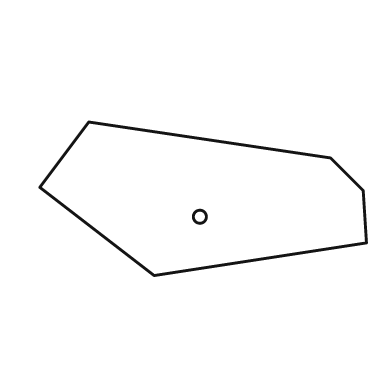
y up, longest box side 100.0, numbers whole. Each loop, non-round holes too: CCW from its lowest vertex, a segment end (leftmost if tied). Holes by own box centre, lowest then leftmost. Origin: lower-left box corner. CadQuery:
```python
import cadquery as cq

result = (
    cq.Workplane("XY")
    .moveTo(35.0, 0.0)
    .lineTo(100.0, 10.0)
    .lineTo(99.0, 26.0)
    .lineTo(89.0, 36.0)
    .lineTo(15.0, 47.0)
    .lineTo(0.0, 27.0)
    .close()
    .moveTo(49.0, 18.0)
    .circle(2.0)
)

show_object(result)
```